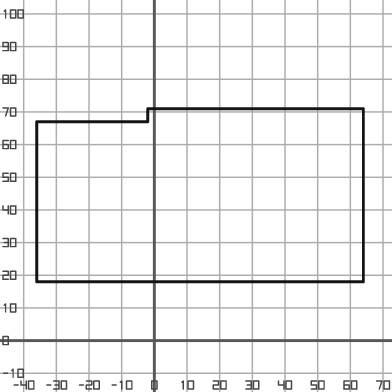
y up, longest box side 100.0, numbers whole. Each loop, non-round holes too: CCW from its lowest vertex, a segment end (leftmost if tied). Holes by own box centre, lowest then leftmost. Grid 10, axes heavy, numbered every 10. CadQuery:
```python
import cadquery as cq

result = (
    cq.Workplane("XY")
    .moveTo(-36.0, 18.0)
    .lineTo(64.0, 18.0)
    .lineTo(64.0, 71.0)
    .lineTo(-2.0, 71.0)
    .lineTo(-2.0, 67.0)
    .lineTo(-36.0, 67.0)
    .close()
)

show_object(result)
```